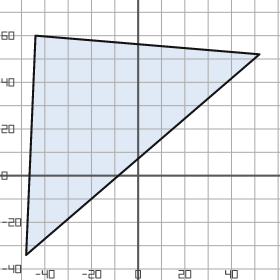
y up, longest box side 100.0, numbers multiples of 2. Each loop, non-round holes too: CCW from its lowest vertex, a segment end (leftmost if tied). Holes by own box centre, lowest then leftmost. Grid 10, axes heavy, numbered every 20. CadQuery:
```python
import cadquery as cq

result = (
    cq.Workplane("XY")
    .moveTo(-48.0, -34.0)
    .lineTo(52.0, 52.0)
    .lineTo(-44.0, 60.0)
    .close()
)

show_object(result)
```